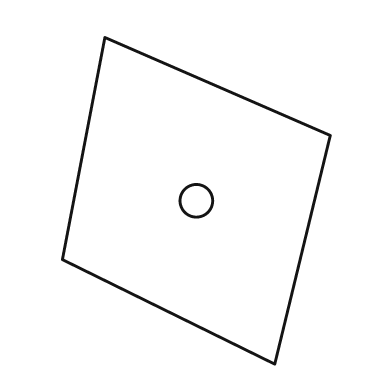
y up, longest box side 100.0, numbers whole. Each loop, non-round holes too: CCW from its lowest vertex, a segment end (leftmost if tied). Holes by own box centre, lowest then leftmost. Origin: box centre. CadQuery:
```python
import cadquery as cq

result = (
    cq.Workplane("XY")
    .moveTo(24.0, -50.0)
    .lineTo(41.0, 20.0)
    .lineTo(-28.0, 50.0)
    .lineTo(-41.0, -18.0)
    .close()
    .moveTo(0.0, 0.0)
    .circle(5.0)
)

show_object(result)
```